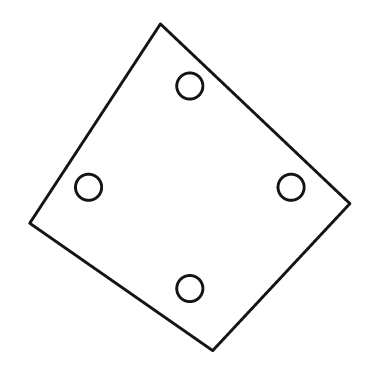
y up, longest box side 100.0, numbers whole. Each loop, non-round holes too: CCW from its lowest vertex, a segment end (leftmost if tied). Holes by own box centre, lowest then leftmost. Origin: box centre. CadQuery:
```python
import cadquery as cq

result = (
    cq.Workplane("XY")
    .moveTo(7.0, -50.0)
    .lineTo(49.0, -5.0)
    .lineTo(-9.0, 50.0)
    .lineTo(-49.0, -11.0)
    .close()
    .moveTo(0.0, -31.0)
    .circle(4.0)
    .moveTo(-31.0, 0.0)
    .circle(4.0)
    .moveTo(31.0, 0.0)
    .circle(4.0)
    .moveTo(0.0, 31.0)
    .circle(4.0)
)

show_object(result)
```